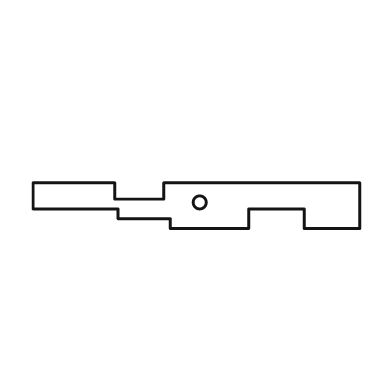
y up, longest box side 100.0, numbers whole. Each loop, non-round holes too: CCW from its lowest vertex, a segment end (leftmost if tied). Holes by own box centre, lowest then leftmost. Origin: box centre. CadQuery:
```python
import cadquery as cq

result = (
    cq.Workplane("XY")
    .moveTo(-8.0, -7.0)
    .lineTo(16.0, -7.0)
    .lineTo(16.0, -1.0)
    .lineTo(33.0, -1.0)
    .lineTo(33.0, -7.0)
    .lineTo(50.0, -7.0)
    .lineTo(50.0, 7.0)
    .lineTo(-10.0, 7.0)
    .lineTo(-10.0, 2.0)
    .lineTo(-25.0, 2.0)
    .lineTo(-25.0, 7.0)
    .lineTo(-50.0, 7.0)
    .lineTo(-50.0, -1.0)
    .lineTo(-24.0, -1.0)
    .lineTo(-24.0, -4.0)
    .lineTo(-8.0, -4.0)
    .close()
    .moveTo(1.0, 1.0)
    .circle(2.0)
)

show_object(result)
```